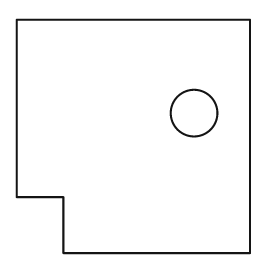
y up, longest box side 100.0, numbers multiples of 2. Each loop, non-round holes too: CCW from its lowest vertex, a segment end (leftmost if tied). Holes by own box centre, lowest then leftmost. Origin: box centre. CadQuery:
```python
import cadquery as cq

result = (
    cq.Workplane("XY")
    .moveTo(-30.0, -50.0)
    .lineTo(50.0, -50.0)
    .lineTo(50.0, 50.0)
    .lineTo(-50.0, 50.0)
    .lineTo(-50.0, -26.0)
    .lineTo(-30.0, -26.0)
    .close()
    .moveTo(26.0, 10.0)
    .circle(10.0)
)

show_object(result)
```